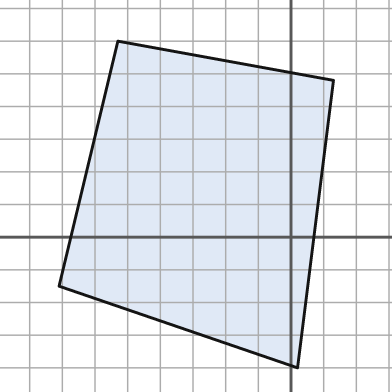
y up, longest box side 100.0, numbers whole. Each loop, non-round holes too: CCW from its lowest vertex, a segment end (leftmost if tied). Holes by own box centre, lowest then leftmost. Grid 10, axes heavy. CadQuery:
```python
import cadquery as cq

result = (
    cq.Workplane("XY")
    .moveTo(2.0, -40.0)
    .lineTo(13.0, 48.0)
    .lineTo(-53.0, 60.0)
    .lineTo(-71.0, -15.0)
    .close()
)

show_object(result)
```